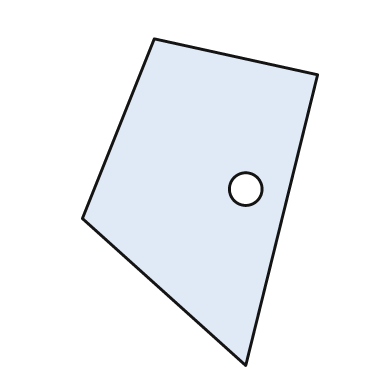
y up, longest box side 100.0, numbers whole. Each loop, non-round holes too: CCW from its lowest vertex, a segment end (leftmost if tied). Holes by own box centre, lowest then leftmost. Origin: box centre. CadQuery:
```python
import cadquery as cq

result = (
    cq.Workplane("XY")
    .moveTo(14.0, -50.0)
    .lineTo(36.0, 39.0)
    .lineTo(-14.0, 50.0)
    .lineTo(-36.0, -5.0)
    .close()
    .moveTo(14.0, 4.0)
    .circle(5.0)
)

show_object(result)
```